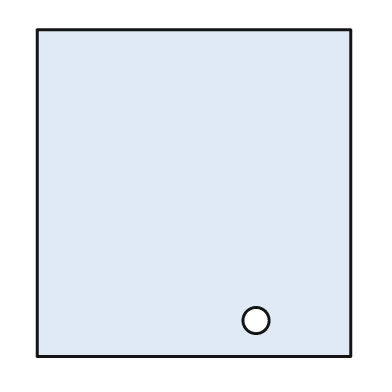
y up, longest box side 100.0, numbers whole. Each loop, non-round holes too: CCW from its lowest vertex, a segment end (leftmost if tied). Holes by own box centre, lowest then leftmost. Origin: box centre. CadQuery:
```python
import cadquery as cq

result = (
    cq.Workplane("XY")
    .moveTo(-48.0, -50.0)
    .lineTo(48.0, -50.0)
    .lineTo(48.0, 50.0)
    .lineTo(-48.0, 50.0)
    .close()
    .moveTo(19.0, -39.0)
    .circle(4.0)
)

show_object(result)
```